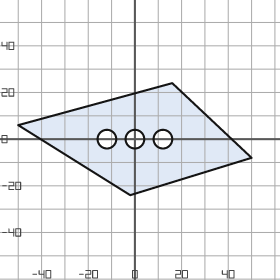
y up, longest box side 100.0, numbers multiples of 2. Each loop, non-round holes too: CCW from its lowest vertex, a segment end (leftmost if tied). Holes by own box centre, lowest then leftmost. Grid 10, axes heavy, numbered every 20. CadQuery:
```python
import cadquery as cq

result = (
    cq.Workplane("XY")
    .moveTo(-2.0, -24.0)
    .lineTo(50.0, -8.0)
    .lineTo(16.0, 24.0)
    .lineTo(-50.0, 6.0)
    .close()
    .moveTo(-12.0, 0.0)
    .circle(4.0)
    .moveTo(0.0, 0.0)
    .circle(4.0)
    .moveTo(12.0, 0.0)
    .circle(4.0)
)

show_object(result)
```